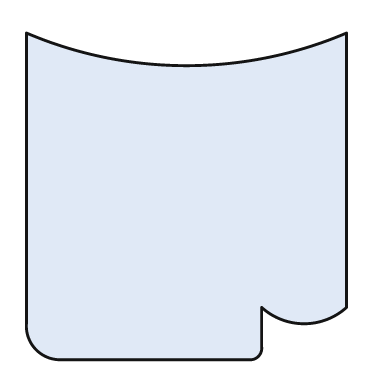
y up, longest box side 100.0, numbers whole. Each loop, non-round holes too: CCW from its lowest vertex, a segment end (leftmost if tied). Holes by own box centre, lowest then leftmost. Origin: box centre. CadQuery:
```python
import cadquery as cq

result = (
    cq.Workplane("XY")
    .moveTo(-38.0, -50.0)
    .lineTo(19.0, -50.0)
    .threePointArc((22.0, -49.0), (23.0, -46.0))
    .lineTo(23.0, -34.0)
    .threePointArc((36.0, -39.0), (49.0, -34.0))
    .lineTo(49.0, 50.0)
    .threePointArc((0.0, 40.0), (-49.0, 50.0))
    .lineTo(-49.0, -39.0)
    .threePointArc((-46.0, -47.0), (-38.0, -50.0))
    .close()
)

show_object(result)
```